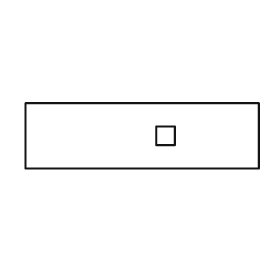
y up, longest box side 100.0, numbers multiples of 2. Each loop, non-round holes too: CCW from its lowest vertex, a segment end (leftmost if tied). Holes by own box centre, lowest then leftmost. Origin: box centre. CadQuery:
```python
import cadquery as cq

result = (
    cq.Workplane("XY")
    .moveTo(-50.0, -14.0)
    .lineTo(50.0, -14.0)
    .lineTo(50.0, 14.0)
    .lineTo(-50.0, 14.0)
    .close()
    .moveTo(6.0, -4.0)
    .lineTo(14.0, -4.0)
    .lineTo(14.0, 4.0)
    .lineTo(6.0, 4.0)
    .close()
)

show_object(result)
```